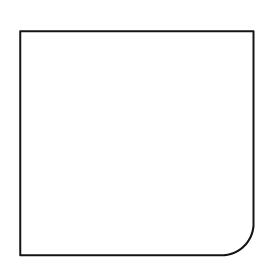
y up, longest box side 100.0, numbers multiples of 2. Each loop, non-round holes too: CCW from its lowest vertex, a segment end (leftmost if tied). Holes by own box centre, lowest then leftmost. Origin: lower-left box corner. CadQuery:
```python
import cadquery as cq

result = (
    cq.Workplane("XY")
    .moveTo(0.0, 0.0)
    .lineTo(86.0, 0.0)
    .threePointArc((96.0, 4.0), (100.0, 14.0))
    .lineTo(100.0, 96.0)
    .lineTo(0.0, 96.0)
    .close()
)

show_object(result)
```